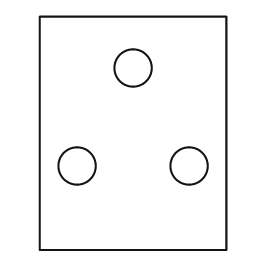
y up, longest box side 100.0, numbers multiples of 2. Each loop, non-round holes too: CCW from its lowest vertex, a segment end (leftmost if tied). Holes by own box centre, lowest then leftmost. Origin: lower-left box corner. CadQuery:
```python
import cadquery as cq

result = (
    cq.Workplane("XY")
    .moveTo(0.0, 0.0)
    .lineTo(80.0, 0.0)
    .lineTo(80.0, 100.0)
    .lineTo(0.0, 100.0)
    .close()
    .moveTo(16.0, 36.0)
    .circle(8.0)
    .moveTo(64.0, 36.0)
    .circle(8.0)
    .moveTo(40.0, 78.0)
    .circle(8.0)
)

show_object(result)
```